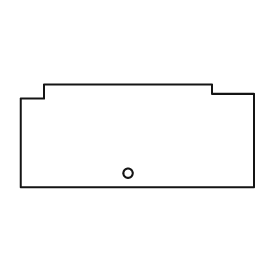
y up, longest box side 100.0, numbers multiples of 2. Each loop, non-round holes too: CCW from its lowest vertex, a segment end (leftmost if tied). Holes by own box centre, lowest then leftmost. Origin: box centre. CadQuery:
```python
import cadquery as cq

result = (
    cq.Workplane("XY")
    .moveTo(-50.0, -22.0)
    .lineTo(50.0, -22.0)
    .lineTo(50.0, 18.0)
    .lineTo(32.0, 18.0)
    .lineTo(32.0, 22.0)
    .lineTo(-40.0, 22.0)
    .lineTo(-40.0, 16.0)
    .lineTo(-50.0, 16.0)
    .close()
    .moveTo(-4.0, -16.0)
    .circle(2.0)
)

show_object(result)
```